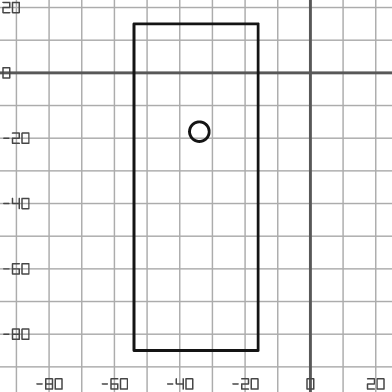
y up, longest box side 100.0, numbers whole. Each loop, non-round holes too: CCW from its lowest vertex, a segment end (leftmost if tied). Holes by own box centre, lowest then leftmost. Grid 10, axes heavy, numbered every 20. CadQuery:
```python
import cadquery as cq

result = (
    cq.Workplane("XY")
    .moveTo(-54.0, -85.0)
    .lineTo(-16.0, -85.0)
    .lineTo(-16.0, 15.0)
    .lineTo(-54.0, 15.0)
    .close()
    .moveTo(-34.0, -18.0)
    .circle(3.0)
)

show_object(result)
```